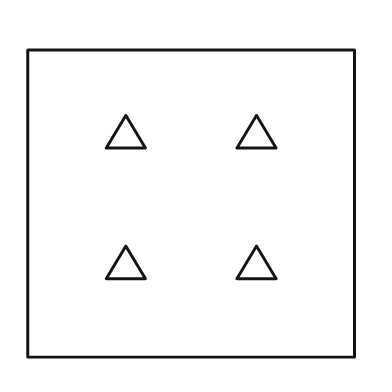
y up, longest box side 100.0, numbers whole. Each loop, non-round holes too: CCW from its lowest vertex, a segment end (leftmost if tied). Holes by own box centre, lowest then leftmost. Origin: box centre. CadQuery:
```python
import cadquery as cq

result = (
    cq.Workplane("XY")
    .moveTo(-50.0, -47.0)
    .lineTo(50.0, -47.0)
    .lineTo(50.0, 47.0)
    .lineTo(-50.0, 47.0)
    .close()
    .moveTo(-26.0, -23.0)
    .lineTo(-14.0, -23.0)
    .lineTo(-20.0, -13.0)
    .close()
    .moveTo(14.0, -23.0)
    .lineTo(26.0, -23.0)
    .lineTo(20.0, -13.0)
    .close()
    .moveTo(-26.0, 17.0)
    .lineTo(-14.0, 17.0)
    .lineTo(-20.0, 27.0)
    .close()
    .moveTo(14.0, 17.0)
    .lineTo(26.0, 17.0)
    .lineTo(20.0, 27.0)
    .close()
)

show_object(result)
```